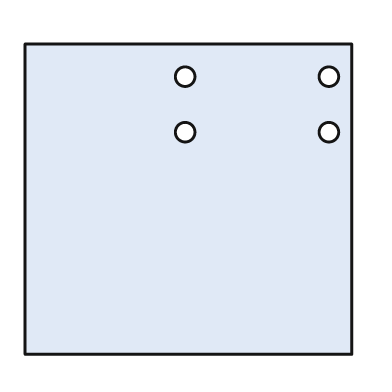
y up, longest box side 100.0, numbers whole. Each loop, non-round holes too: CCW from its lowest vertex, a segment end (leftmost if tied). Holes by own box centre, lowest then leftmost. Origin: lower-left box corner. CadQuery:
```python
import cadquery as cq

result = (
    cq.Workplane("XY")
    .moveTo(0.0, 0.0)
    .lineTo(100.0, 0.0)
    .lineTo(100.0, 95.0)
    .lineTo(0.0, 95.0)
    .close()
    .moveTo(49.0, 68.0)
    .circle(3.0)
    .moveTo(93.0, 68.0)
    .circle(3.0)
    .moveTo(49.0, 85.0)
    .circle(3.0)
    .moveTo(93.0, 85.0)
    .circle(3.0)
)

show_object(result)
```